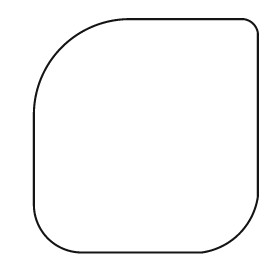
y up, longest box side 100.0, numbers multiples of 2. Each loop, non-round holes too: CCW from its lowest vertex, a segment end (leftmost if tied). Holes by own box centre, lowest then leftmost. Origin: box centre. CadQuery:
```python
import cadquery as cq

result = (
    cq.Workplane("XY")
    .moveTo(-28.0, -50.0)
    .lineTo(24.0, -50.0)
    .threePointArc((40.0, -42.0), (48.0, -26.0))
    .lineTo(48.0, 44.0)
    .threePointArc((46.0, 48.0), (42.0, 50.0))
    .lineTo(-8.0, 50.0)
    .threePointArc((-36.0, 38.0), (-48.0, 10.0))
    .lineTo(-48.0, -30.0)
    .threePointArc((-42.0, -44.0), (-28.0, -50.0))
    .close()
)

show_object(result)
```